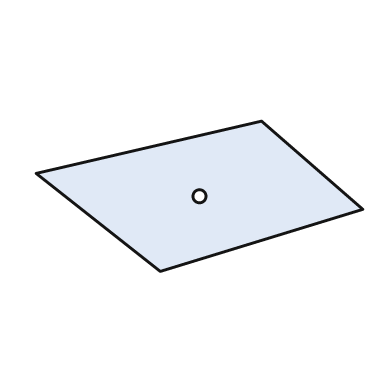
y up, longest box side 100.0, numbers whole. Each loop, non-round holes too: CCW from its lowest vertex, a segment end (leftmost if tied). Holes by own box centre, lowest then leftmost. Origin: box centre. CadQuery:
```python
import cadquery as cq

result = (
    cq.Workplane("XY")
    .moveTo(-12.0, -23.0)
    .lineTo(50.0, -4.0)
    .lineTo(19.0, 23.0)
    .lineTo(-50.0, 7.0)
    .close()
    .moveTo(0.0, 0.0)
    .circle(2.0)
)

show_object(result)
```